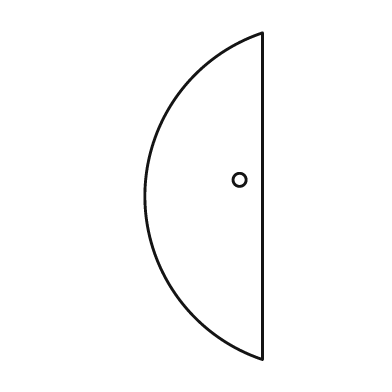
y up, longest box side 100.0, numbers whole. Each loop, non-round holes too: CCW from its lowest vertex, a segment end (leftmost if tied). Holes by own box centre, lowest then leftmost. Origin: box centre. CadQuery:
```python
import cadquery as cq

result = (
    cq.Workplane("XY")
    .moveTo(18.0, -50.0)
    .lineTo(18.0, 50.0)
    .threePointArc((-18.0, 0.0), (18.0, -50.0))
    .close()
    .moveTo(11.0, 5.0)
    .circle(2.0)
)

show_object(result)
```